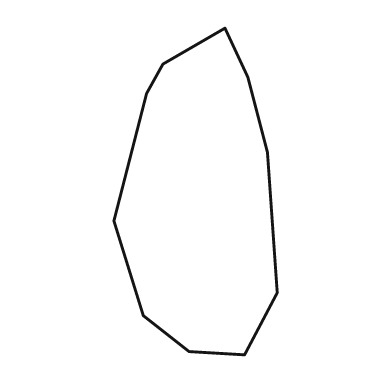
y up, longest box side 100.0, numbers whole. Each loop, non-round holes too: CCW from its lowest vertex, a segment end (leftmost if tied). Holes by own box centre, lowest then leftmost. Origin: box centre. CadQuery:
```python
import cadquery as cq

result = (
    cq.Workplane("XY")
    .moveTo(15.0, -50.0)
    .lineTo(25.0, -31.0)
    .lineTo(22.0, 12.0)
    .lineTo(16.0, 35.0)
    .lineTo(9.0, 50.0)
    .lineTo(-10.0, 39.0)
    .lineTo(-15.0, 30.0)
    .lineTo(-25.0, -9.0)
    .lineTo(-16.0, -38.0)
    .lineTo(-2.0, -49.0)
    .close()
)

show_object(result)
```